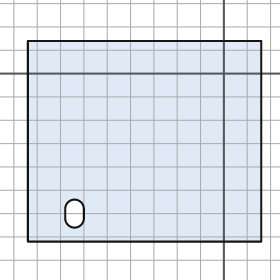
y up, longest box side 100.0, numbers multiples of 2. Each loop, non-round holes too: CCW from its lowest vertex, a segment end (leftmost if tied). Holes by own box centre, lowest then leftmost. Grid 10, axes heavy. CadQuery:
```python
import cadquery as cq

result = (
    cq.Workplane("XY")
    .moveTo(-84.0, -72.0)
    .lineTo(16.0, -72.0)
    .lineTo(16.0, 14.0)
    .lineTo(-84.0, 14.0)
    .close()
    .moveTo(-68.0, -62.0)
    .threePointArc((-64.0, -66.0), (-60.0, -62.0))
    .lineTo(-60.0, -58.0)
    .threePointArc((-64.0, -54.0), (-68.0, -58.0))
    .close()
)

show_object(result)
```